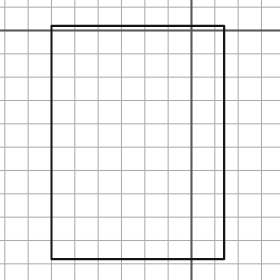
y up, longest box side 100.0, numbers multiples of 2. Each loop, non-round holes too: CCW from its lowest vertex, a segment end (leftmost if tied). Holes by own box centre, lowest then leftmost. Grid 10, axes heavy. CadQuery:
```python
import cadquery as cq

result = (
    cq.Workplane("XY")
    .moveTo(-60.0, -98.0)
    .lineTo(14.0, -98.0)
    .lineTo(14.0, 2.0)
    .lineTo(-60.0, 2.0)
    .close()
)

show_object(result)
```